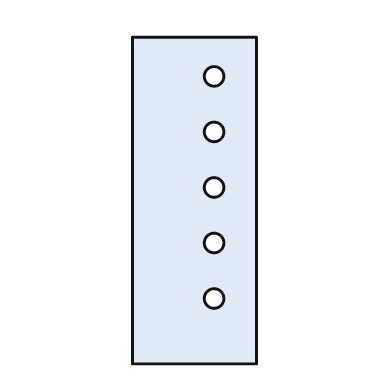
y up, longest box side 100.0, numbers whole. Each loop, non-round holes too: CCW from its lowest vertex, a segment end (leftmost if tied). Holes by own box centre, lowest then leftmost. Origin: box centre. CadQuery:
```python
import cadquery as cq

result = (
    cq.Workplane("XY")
    .moveTo(-19.0, -50.0)
    .lineTo(19.0, -50.0)
    .lineTo(19.0, 50.0)
    .lineTo(-19.0, 50.0)
    .close()
    .moveTo(6.0, -30.0)
    .circle(3.0)
    .moveTo(6.0, -13.0)
    .circle(3.0)
    .moveTo(6.0, 4.0)
    .circle(3.0)
    .moveTo(6.0, 21.0)
    .circle(3.0)
    .moveTo(6.0, 38.0)
    .circle(3.0)
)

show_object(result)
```